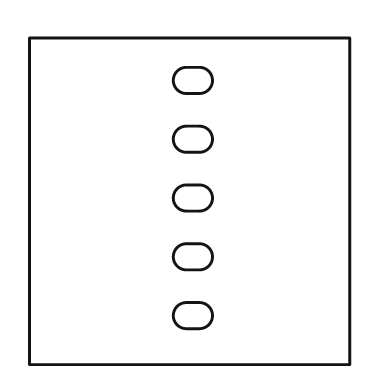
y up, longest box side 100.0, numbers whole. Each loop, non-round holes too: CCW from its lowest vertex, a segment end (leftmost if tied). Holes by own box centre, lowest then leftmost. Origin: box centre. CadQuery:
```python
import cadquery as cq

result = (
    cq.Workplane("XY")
    .moveTo(-49.0, -50.0)
    .lineTo(49.0, -50.0)
    .lineTo(49.0, 50.0)
    .lineTo(-49.0, 50.0)
    .close()
    .moveTo(-1.0, -39.0)
    .lineTo(3.0, -39.0)
    .threePointArc((7.0, -35.0), (3.0, -31.0))
    .lineTo(-1.0, -31.0)
    .threePointArc((-5.0, -35.0), (-1.0, -39.0))
    .close()
    .moveTo(-1.0, -21.0)
    .lineTo(3.0, -21.0)
    .threePointArc((7.0, -17.0), (3.0, -13.0))
    .lineTo(-1.0, -13.0)
    .threePointArc((-5.0, -17.0), (-1.0, -21.0))
    .close()
    .moveTo(-1.0, -3.0)
    .lineTo(3.0, -3.0)
    .threePointArc((7.0, 1.0), (3.0, 5.0))
    .lineTo(-1.0, 5.0)
    .threePointArc((-5.0, 1.0), (-1.0, -3.0))
    .close()
    .moveTo(-1.0, 15.0)
    .lineTo(3.0, 15.0)
    .threePointArc((7.0, 19.0), (3.0, 23.0))
    .lineTo(-1.0, 23.0)
    .threePointArc((-5.0, 19.0), (-1.0, 15.0))
    .close()
    .moveTo(-1.0, 33.0)
    .lineTo(3.0, 33.0)
    .threePointArc((7.0, 37.0), (3.0, 41.0))
    .lineTo(-1.0, 41.0)
    .threePointArc((-5.0, 37.0), (-1.0, 33.0))
    .close()
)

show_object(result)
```